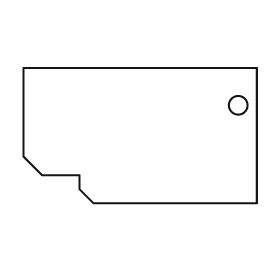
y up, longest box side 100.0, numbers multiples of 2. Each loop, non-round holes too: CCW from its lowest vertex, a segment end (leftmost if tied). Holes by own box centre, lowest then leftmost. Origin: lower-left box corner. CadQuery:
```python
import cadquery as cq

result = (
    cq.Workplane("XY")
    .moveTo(30.0, 0.0)
    .lineTo(100.0, 0.0)
    .lineTo(100.0, 58.0)
    .lineTo(0.0, 58.0)
    .lineTo(0.0, 20.0)
    .lineTo(8.0, 12.0)
    .lineTo(24.0, 12.0)
    .lineTo(24.0, 6.0)
    .close()
    .moveTo(92.0, 42.0)
    .circle(4.0)
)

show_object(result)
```